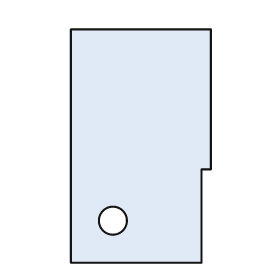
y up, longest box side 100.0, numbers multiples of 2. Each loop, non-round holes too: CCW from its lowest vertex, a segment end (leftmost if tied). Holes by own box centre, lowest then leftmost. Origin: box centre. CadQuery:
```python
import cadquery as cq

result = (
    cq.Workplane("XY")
    .moveTo(-30.0, -50.0)
    .lineTo(26.0, -50.0)
    .lineTo(26.0, -10.0)
    .lineTo(30.0, -10.0)
    .lineTo(30.0, 50.0)
    .lineTo(-30.0, 50.0)
    .close()
    .moveTo(-12.0, -32.0)
    .circle(6.0)
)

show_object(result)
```